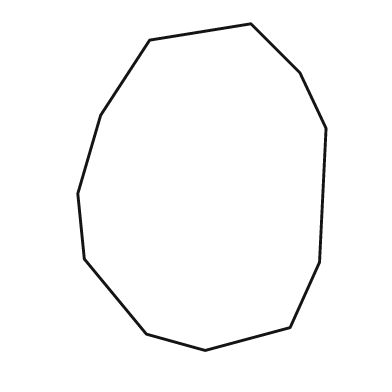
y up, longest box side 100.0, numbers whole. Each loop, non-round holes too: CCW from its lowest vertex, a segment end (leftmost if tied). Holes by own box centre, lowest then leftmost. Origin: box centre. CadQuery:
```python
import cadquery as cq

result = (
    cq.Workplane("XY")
    .moveTo(1.0, -50.0)
    .lineTo(27.0, -43.0)
    .lineTo(36.0, -23.0)
    .lineTo(38.0, 18.0)
    .lineTo(30.0, 35.0)
    .lineTo(15.0, 50.0)
    .lineTo(-16.0, 45.0)
    .lineTo(-31.0, 22.0)
    .lineTo(-38.0, -2.0)
    .lineTo(-36.0, -22.0)
    .lineTo(-17.0, -45.0)
    .close()
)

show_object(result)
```